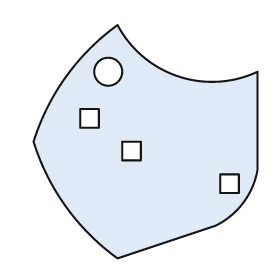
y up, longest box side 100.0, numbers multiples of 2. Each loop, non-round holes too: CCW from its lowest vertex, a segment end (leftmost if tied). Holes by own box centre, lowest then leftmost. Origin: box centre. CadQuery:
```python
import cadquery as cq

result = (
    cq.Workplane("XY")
    .moveTo(-12.0, -50.0)
    .lineTo(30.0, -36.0)
    .threePointArc((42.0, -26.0), (48.0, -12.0))
    .lineTo(48.0, 30.0)
    .threePointArc((14.0, 28.0), (-12.0, 50.0))
    .threePointArc((-34.0, 28.0), (-48.0, 0.0))
    .threePointArc((-34.0, -28.0), (-12.0, -50.0))
    .close()
    .moveTo(32.0, -22.0)
    .lineTo(40.0, -22.0)
    .lineTo(40.0, -14.0)
    .lineTo(32.0, -14.0)
    .close()
    .moveTo(-10.0, -8.0)
    .lineTo(-2.0, -8.0)
    .lineTo(-2.0, 0.0)
    .lineTo(-10.0, 0.0)
    .close()
    .moveTo(-28.0, 6.0)
    .lineTo(-20.0, 6.0)
    .lineTo(-20.0, 14.0)
    .lineTo(-28.0, 14.0)
    .close()
    .moveTo(-16.0, 30.0)
    .circle(6.0)
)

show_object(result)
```